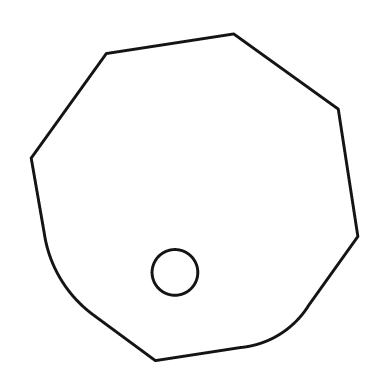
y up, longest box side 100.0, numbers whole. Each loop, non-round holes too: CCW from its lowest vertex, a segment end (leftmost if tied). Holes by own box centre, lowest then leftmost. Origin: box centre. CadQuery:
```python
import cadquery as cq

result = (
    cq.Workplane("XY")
    .moveTo(-12.0, -50.0)
    .lineTo(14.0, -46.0)
    .threePointArc((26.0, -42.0), (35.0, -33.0))
    .lineTo(50.0, -12.0)
    .lineTo(44.0, 27.0)
    .lineTo(12.0, 50.0)
    .lineTo(-27.0, 44.0)
    .lineTo(-50.0, 12.0)
    .lineTo(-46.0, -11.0)
    .threePointArc((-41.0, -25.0), (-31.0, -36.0))
    .close()
    .moveTo(-6.0, -23.0)
    .circle(7.0)
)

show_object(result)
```